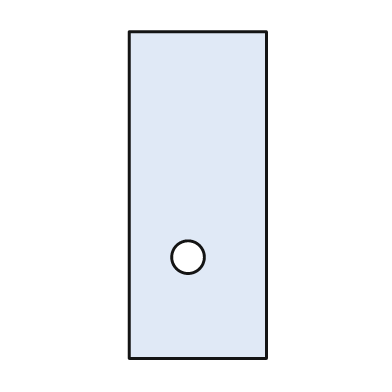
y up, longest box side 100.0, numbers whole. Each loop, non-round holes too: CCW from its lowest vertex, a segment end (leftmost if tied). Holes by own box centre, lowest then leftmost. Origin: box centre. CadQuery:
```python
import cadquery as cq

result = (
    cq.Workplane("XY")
    .moveTo(-21.0, -50.0)
    .lineTo(21.0, -50.0)
    .lineTo(21.0, 50.0)
    .lineTo(-21.0, 50.0)
    .close()
    .moveTo(-3.0, -19.0)
    .circle(5.0)
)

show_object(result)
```